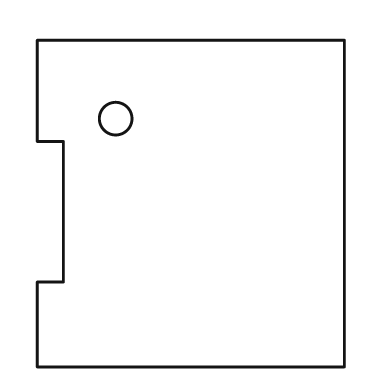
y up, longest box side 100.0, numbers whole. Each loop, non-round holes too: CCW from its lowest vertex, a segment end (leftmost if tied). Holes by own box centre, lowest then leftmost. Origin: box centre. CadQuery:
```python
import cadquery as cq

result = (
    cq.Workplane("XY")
    .moveTo(-47.0, -50.0)
    .lineTo(47.0, -50.0)
    .lineTo(47.0, 50.0)
    .lineTo(-47.0, 50.0)
    .lineTo(-47.0, 19.0)
    .lineTo(-39.0, 19.0)
    .lineTo(-39.0, -24.0)
    .lineTo(-47.0, -24.0)
    .close()
    .moveTo(-23.0, 26.0)
    .circle(5.0)
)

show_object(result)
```